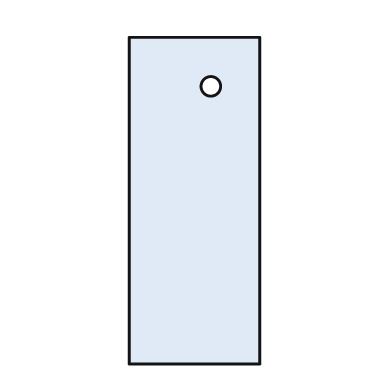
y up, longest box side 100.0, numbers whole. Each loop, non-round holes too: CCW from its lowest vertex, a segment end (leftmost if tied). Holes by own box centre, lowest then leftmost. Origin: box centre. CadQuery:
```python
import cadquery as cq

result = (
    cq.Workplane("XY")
    .moveTo(-20.0, -50.0)
    .lineTo(20.0, -50.0)
    .lineTo(20.0, 50.0)
    .lineTo(-20.0, 50.0)
    .close()
    .moveTo(5.0, 35.0)
    .circle(3.0)
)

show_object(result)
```